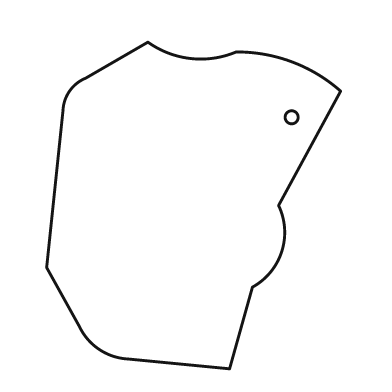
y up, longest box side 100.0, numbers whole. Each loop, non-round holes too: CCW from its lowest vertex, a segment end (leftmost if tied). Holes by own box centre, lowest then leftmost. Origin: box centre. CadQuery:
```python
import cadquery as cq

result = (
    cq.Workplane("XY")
    .moveTo(11.0, -50.0)
    .lineTo(18.0, -25.0)
    .threePointArc((27.0, -14.0), (26.0, 0.0))
    .lineTo(45.0, 35.0)
    .threePointArc((30.0, 44.0), (13.0, 47.0))
    .threePointArc((-1.0, 45.0), (-14.0, 50.0))
    .lineTo(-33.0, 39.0)
    .threePointArc((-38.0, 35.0), (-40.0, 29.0))
    .lineTo(-45.0, -19.0)
    .lineTo(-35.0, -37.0)
    .threePointArc((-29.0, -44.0), (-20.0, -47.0))
    .close()
    .moveTo(30.0, 27.0)
    .circle(2.0)
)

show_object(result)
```